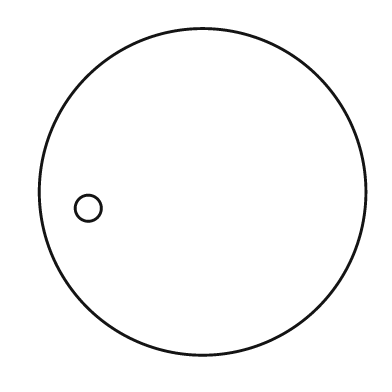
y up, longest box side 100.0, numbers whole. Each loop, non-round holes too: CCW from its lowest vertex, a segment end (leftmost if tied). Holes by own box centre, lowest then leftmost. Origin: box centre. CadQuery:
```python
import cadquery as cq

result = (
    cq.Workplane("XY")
    .moveTo(0.0, 0.0)
    .circle(50.0)
    .moveTo(-35.0, -5.0)
    .circle(4.0)
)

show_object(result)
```